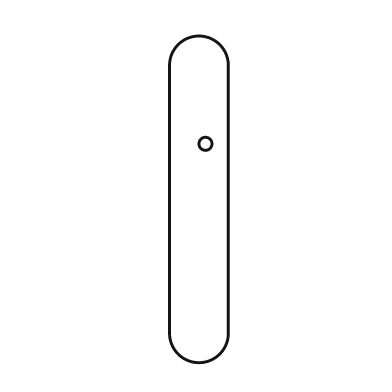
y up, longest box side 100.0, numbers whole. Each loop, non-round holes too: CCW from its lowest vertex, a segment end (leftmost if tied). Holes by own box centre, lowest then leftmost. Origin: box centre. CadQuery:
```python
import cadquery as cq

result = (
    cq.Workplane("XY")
    .moveTo(-9.0, -41.0)
    .threePointArc((0.0, -50.0), (9.0, -41.0))
    .lineTo(9.0, 41.0)
    .threePointArc((0.0, 50.0), (-9.0, 41.0))
    .close()
    .moveTo(2.0, 17.0)
    .circle(2.0)
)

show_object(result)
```